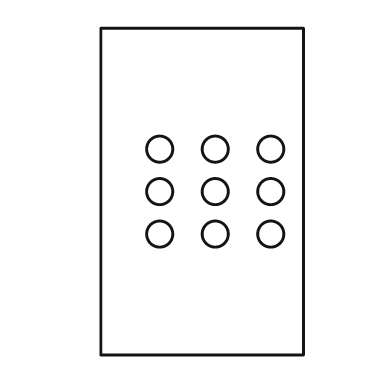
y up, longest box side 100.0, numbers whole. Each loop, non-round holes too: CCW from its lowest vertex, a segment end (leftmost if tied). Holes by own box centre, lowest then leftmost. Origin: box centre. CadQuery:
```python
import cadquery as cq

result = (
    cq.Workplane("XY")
    .moveTo(-31.0, -50.0)
    .lineTo(31.0, -50.0)
    .lineTo(31.0, 50.0)
    .lineTo(-31.0, 50.0)
    .close()
    .moveTo(-13.0, -13.0)
    .circle(4.0)
    .moveTo(4.0, -13.0)
    .circle(4.0)
    .moveTo(21.0, -13.0)
    .circle(4.0)
    .moveTo(-13.0, 0.0)
    .circle(4.0)
    .moveTo(4.0, 0.0)
    .circle(4.0)
    .moveTo(21.0, 0.0)
    .circle(4.0)
    .moveTo(-13.0, 13.0)
    .circle(4.0)
    .moveTo(4.0, 13.0)
    .circle(4.0)
    .moveTo(21.0, 13.0)
    .circle(4.0)
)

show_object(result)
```